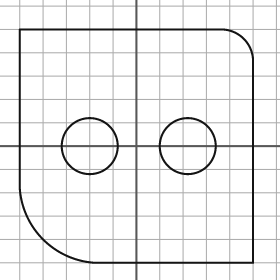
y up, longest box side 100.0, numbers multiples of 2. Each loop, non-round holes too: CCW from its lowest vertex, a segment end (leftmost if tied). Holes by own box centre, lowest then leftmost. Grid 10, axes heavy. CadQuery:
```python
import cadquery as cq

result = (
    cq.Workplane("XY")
    .moveTo(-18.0, -50.0)
    .lineTo(50.0, -50.0)
    .lineTo(50.0, 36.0)
    .threePointArc((46.0, 46.0), (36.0, 50.0))
    .lineTo(-50.0, 50.0)
    .lineTo(-50.0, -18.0)
    .threePointArc((-40.0, -40.0), (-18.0, -50.0))
    .close()
    .moveTo(-20.0, 0.0)
    .circle(12.0)
    .moveTo(22.0, 0.0)
    .circle(12.0)
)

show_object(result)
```